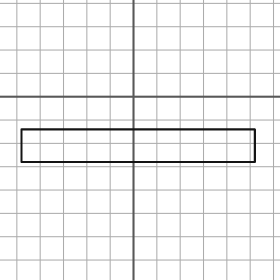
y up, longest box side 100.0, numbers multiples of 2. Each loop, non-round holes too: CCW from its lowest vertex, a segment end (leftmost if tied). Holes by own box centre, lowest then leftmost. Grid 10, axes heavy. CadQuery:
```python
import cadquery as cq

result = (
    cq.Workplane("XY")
    .moveTo(-48.0, -28.0)
    .lineTo(52.0, -28.0)
    .lineTo(52.0, -14.0)
    .lineTo(-48.0, -14.0)
    .close()
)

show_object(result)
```